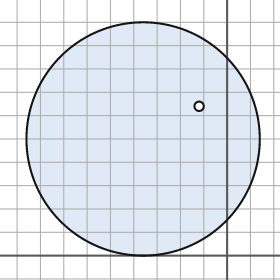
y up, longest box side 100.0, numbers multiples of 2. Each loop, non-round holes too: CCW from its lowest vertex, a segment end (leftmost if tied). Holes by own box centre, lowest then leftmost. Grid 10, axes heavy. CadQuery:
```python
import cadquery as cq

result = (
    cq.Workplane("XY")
    .moveTo(-36.0, 50.0)
    .circle(50.0)
    .moveTo(-12.0, 64.0)
    .circle(2.0)
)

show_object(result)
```